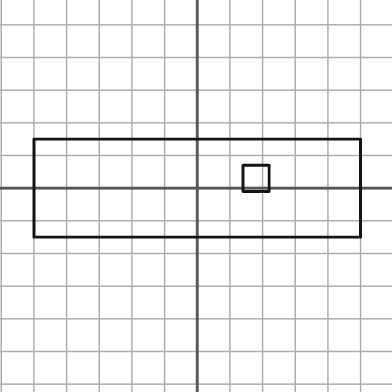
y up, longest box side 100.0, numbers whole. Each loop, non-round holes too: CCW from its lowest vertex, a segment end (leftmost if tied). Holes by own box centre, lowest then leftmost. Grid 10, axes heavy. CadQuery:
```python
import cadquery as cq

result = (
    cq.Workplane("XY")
    .moveTo(-50.0, -15.0)
    .lineTo(50.0, -15.0)
    .lineTo(50.0, 15.0)
    .lineTo(-50.0, 15.0)
    .close()
    .moveTo(14.0, -1.0)
    .lineTo(22.0, -1.0)
    .lineTo(22.0, 7.0)
    .lineTo(14.0, 7.0)
    .close()
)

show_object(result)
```